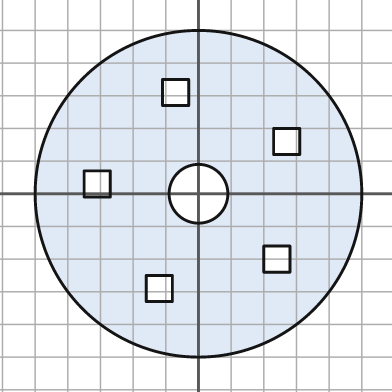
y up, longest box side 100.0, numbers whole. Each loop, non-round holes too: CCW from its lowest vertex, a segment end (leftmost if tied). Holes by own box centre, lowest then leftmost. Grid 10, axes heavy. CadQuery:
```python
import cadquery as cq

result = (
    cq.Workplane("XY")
    .moveTo(0.0, 0.0)
    .circle(50.0)
    .moveTo(-16.0, -33.0)
    .lineTo(-8.0, -33.0)
    .lineTo(-8.0, -25.0)
    .lineTo(-16.0, -25.0)
    .close()
    .moveTo(20.0, -24.0)
    .lineTo(28.0, -24.0)
    .lineTo(28.0, -16.0)
    .lineTo(20.0, -16.0)
    .close()
    .moveTo(0.0, 0.0)
    .circle(9.0)
    .moveTo(-35.0, -1.0)
    .lineTo(-27.0, -1.0)
    .lineTo(-27.0, 7.0)
    .lineTo(-35.0, 7.0)
    .close()
    .moveTo(23.0, 12.0)
    .lineTo(31.0, 12.0)
    .lineTo(31.0, 20.0)
    .lineTo(23.0, 20.0)
    .close()
    .moveTo(-11.0, 27.0)
    .lineTo(-3.0, 27.0)
    .lineTo(-3.0, 35.0)
    .lineTo(-11.0, 35.0)
    .close()
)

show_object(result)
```